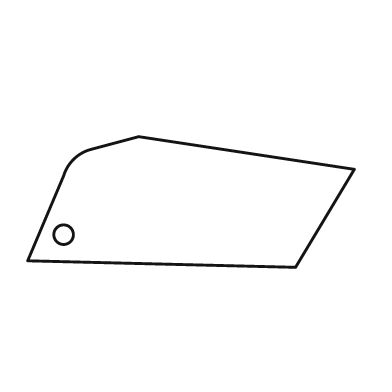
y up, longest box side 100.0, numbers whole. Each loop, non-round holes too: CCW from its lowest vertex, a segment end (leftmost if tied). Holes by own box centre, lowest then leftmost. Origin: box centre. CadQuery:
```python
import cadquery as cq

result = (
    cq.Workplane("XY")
    .moveTo(32.0, -20.0)
    .lineTo(50.0, 10.0)
    .lineTo(-16.0, 20.0)
    .lineTo(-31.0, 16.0)
    .threePointArc((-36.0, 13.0), (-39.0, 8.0))
    .lineTo(-50.0, -18.0)
    .close()
    .moveTo(-39.0, -10.0)
    .circle(3.0)
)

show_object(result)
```